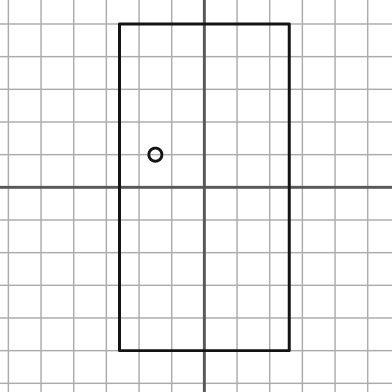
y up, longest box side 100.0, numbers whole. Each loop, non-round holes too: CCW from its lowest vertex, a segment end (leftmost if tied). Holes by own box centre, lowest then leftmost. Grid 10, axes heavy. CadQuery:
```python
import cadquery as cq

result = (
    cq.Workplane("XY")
    .moveTo(-26.0, -50.0)
    .lineTo(26.0, -50.0)
    .lineTo(26.0, 50.0)
    .lineTo(-26.0, 50.0)
    .close()
    .moveTo(-15.0, 10.0)
    .circle(2.0)
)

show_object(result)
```